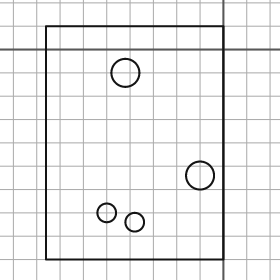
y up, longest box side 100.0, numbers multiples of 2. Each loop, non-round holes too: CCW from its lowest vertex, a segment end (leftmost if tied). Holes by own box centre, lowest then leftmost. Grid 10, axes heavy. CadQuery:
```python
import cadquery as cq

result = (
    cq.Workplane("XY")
    .moveTo(-76.0, -90.0)
    .lineTo(0.0, -90.0)
    .lineTo(0.0, 10.0)
    .lineTo(-76.0, 10.0)
    .close()
    .moveTo(-38.0, -74.0)
    .circle(4.0)
    .moveTo(-50.0, -70.0)
    .circle(4.0)
    .moveTo(-10.0, -54.0)
    .circle(6.0)
    .moveTo(-42.0, -10.0)
    .circle(6.0)
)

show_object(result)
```